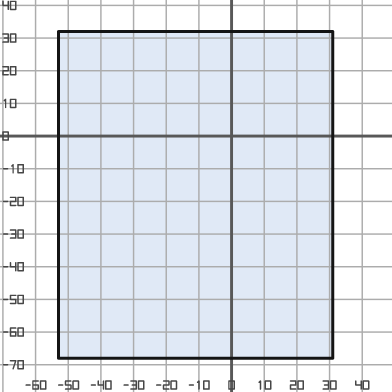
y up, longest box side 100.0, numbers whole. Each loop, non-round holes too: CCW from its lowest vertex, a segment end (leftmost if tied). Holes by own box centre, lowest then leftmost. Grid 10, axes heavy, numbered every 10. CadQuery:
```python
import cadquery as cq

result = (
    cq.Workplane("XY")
    .moveTo(-53.0, -68.0)
    .lineTo(31.0, -68.0)
    .lineTo(31.0, 32.0)
    .lineTo(-53.0, 32.0)
    .close()
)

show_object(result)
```